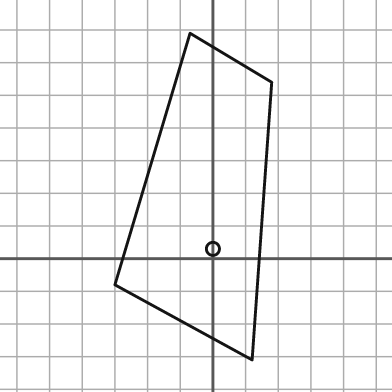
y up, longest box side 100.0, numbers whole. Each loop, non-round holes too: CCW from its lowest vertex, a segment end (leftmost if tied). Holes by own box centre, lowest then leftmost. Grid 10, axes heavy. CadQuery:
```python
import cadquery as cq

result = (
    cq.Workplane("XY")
    .moveTo(12.0, -31.0)
    .lineTo(18.0, 54.0)
    .lineTo(-7.0, 69.0)
    .lineTo(-30.0, -8.0)
    .close()
    .moveTo(0.0, 3.0)
    .circle(2.0)
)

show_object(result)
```